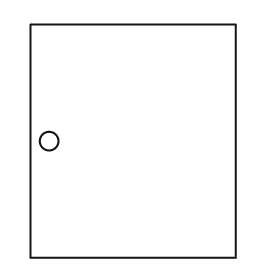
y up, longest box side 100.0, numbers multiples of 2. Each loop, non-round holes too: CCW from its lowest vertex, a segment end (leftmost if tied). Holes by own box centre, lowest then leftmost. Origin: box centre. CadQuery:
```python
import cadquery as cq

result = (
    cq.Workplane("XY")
    .moveTo(-44.0, -50.0)
    .lineTo(44.0, -50.0)
    .lineTo(44.0, 50.0)
    .lineTo(-44.0, 50.0)
    .close()
    .moveTo(-36.0, 0.0)
    .circle(4.0)
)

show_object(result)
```